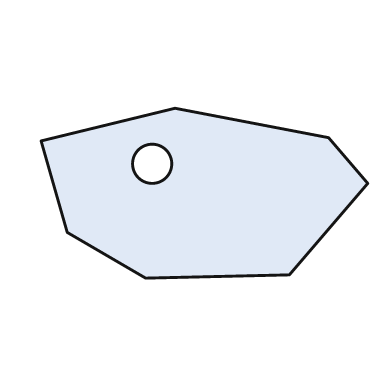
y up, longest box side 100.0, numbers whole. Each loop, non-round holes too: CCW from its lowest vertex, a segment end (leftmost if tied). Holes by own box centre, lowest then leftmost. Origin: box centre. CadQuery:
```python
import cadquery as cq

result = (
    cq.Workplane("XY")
    .moveTo(-18.0, -26.0)
    .lineTo(26.0, -25.0)
    .lineTo(50.0, 3.0)
    .lineTo(38.0, 17.0)
    .lineTo(-9.0, 26.0)
    .lineTo(-50.0, 16.0)
    .lineTo(-42.0, -12.0)
    .close()
    .moveTo(-16.0, 9.0)
    .circle(6.0)
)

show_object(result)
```